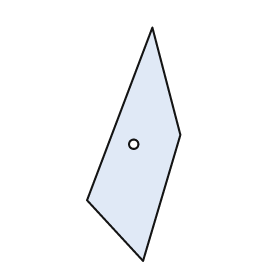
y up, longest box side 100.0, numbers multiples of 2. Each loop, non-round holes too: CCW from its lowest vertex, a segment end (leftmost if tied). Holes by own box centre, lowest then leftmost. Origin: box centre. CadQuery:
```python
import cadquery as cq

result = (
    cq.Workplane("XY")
    .moveTo(4.0, -50.0)
    .lineTo(20.0, 4.0)
    .lineTo(8.0, 50.0)
    .lineTo(-20.0, -24.0)
    .close()
    .moveTo(0.0, 0.0)
    .circle(2.0)
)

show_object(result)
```